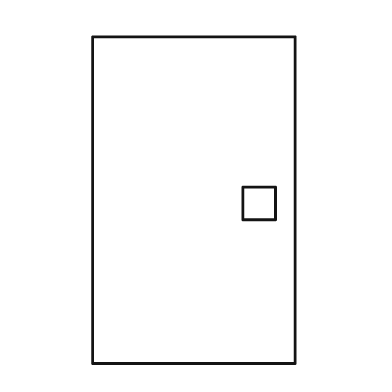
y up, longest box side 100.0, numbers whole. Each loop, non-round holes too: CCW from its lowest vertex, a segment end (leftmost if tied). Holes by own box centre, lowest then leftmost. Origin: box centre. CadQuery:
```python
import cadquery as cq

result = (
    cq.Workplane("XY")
    .moveTo(-31.0, -50.0)
    .lineTo(31.0, -50.0)
    .lineTo(31.0, 50.0)
    .lineTo(-31.0, 50.0)
    .close()
    .moveTo(15.0, -6.0)
    .lineTo(25.0, -6.0)
    .lineTo(25.0, 4.0)
    .lineTo(15.0, 4.0)
    .close()
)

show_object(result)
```